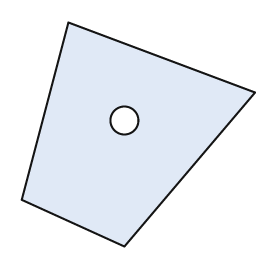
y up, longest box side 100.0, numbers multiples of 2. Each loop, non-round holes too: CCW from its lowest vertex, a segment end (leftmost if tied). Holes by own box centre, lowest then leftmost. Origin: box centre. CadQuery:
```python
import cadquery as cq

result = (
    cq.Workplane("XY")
    .moveTo(-6.0, -48.0)
    .lineTo(50.0, 18.0)
    .lineTo(-30.0, 48.0)
    .lineTo(-50.0, -28.0)
    .close()
    .moveTo(-6.0, 6.0)
    .circle(6.0)
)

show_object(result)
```